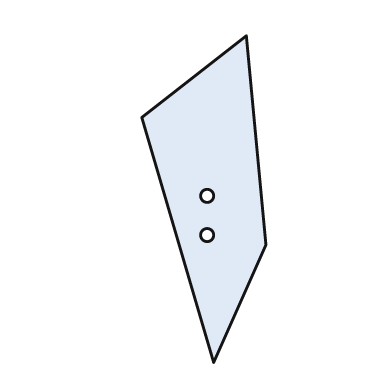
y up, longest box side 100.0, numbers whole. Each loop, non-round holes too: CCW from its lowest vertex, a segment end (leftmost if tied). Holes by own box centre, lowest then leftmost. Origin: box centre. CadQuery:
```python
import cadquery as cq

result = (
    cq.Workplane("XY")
    .moveTo(3.0, -50.0)
    .lineTo(19.0, -14.0)
    .lineTo(13.0, 50.0)
    .lineTo(-19.0, 25.0)
    .close()
    .moveTo(1.0, -11.0)
    .circle(2.0)
    .moveTo(1.0, 1.0)
    .circle(2.0)
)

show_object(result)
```